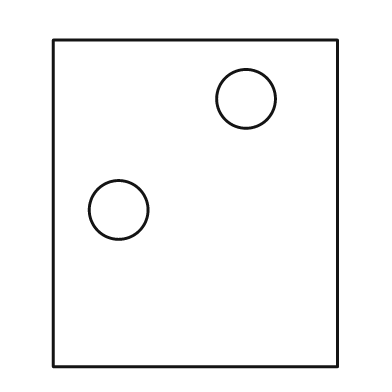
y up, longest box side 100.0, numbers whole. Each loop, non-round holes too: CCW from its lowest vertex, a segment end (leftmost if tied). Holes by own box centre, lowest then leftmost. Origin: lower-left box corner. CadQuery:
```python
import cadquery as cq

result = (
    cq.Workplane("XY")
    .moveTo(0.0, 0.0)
    .lineTo(87.0, 0.0)
    .lineTo(87.0, 100.0)
    .lineTo(0.0, 100.0)
    .close()
    .moveTo(20.0, 48.0)
    .circle(9.0)
    .moveTo(59.0, 82.0)
    .circle(9.0)
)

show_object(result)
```